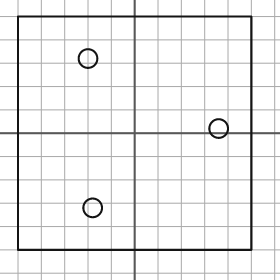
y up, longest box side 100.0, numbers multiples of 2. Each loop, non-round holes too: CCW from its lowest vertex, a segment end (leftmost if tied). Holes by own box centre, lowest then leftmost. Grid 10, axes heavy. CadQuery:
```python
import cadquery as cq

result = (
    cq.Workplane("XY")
    .moveTo(-50.0, -50.0)
    .lineTo(50.0, -50.0)
    .lineTo(50.0, 50.0)
    .lineTo(-50.0, 50.0)
    .close()
    .moveTo(-18.0, -32.0)
    .circle(4.0)
    .moveTo(36.0, 2.0)
    .circle(4.0)
    .moveTo(-20.0, 32.0)
    .circle(4.0)
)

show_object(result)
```